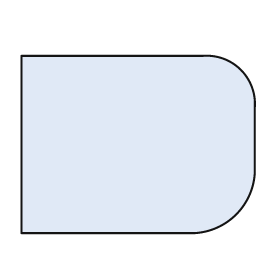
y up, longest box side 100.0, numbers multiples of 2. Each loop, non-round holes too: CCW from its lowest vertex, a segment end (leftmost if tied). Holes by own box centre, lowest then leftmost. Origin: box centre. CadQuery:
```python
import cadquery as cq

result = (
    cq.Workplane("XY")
    .moveTo(-50.0, -38.0)
    .lineTo(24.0, -38.0)
    .threePointArc((42.0, -30.0), (50.0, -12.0))
    .lineTo(50.0, 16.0)
    .threePointArc((44.0, 32.0), (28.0, 38.0))
    .lineTo(-50.0, 38.0)
    .close()
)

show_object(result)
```